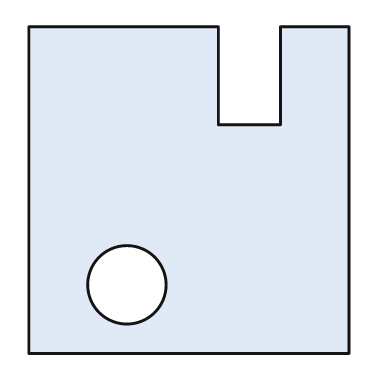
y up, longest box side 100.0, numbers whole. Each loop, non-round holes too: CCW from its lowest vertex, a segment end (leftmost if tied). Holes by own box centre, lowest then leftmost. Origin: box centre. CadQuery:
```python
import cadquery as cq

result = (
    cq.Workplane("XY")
    .moveTo(-49.0, -50.0)
    .lineTo(49.0, -50.0)
    .lineTo(49.0, 50.0)
    .lineTo(28.0, 50.0)
    .lineTo(28.0, 20.0)
    .lineTo(9.0, 20.0)
    .lineTo(9.0, 50.0)
    .lineTo(-49.0, 50.0)
    .close()
    .moveTo(-19.0, -29.0)
    .circle(12.0)
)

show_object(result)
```